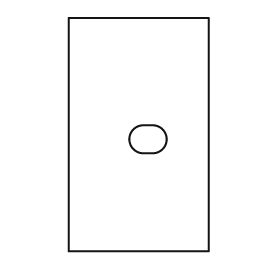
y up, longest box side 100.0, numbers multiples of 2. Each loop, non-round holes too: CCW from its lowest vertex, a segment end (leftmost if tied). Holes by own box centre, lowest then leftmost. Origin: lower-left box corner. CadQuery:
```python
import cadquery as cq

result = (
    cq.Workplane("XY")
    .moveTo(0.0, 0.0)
    .lineTo(60.0, 0.0)
    .lineTo(60.0, 100.0)
    .lineTo(0.0, 100.0)
    .close()
    .moveTo(32.0, 42.0)
    .lineTo(36.0, 42.0)
    .threePointArc((42.0, 48.0), (36.0, 54.0))
    .lineTo(32.0, 54.0)
    .threePointArc((26.0, 48.0), (32.0, 42.0))
    .close()
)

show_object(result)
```